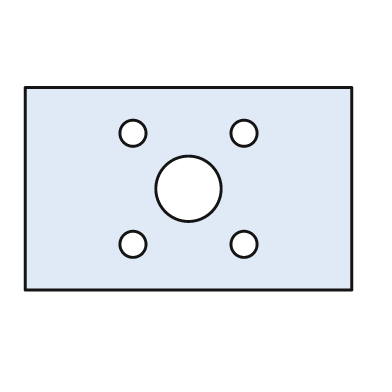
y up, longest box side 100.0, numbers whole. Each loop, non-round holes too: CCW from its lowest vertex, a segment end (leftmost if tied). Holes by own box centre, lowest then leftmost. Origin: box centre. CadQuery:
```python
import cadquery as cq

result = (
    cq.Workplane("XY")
    .moveTo(-50.0, -31.0)
    .lineTo(50.0, -31.0)
    .lineTo(50.0, 31.0)
    .lineTo(-50.0, 31.0)
    .close()
    .moveTo(-17.0, -17.0)
    .circle(4.0)
    .moveTo(17.0, -17.0)
    .circle(4.0)
    .moveTo(0.0, 0.0)
    .circle(10.0)
    .moveTo(-17.0, 17.0)
    .circle(4.0)
    .moveTo(17.0, 17.0)
    .circle(4.0)
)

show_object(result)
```